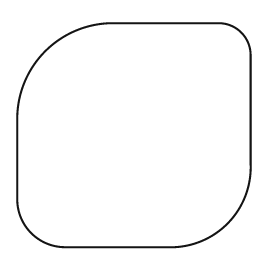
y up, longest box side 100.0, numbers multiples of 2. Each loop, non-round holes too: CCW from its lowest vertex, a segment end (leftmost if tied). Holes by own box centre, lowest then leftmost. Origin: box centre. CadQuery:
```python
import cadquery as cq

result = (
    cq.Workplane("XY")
    .moveTo(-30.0, -48.0)
    .lineTo(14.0, -48.0)
    .threePointArc((40.0, -38.0), (50.0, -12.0))
    .lineTo(50.0, 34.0)
    .threePointArc((46.0, 44.0), (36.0, 48.0))
    .lineTo(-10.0, 48.0)
    .threePointArc((-38.0, 36.0), (-50.0, 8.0))
    .lineTo(-50.0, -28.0)
    .threePointArc((-44.0, -42.0), (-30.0, -48.0))
    .close()
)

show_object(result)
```